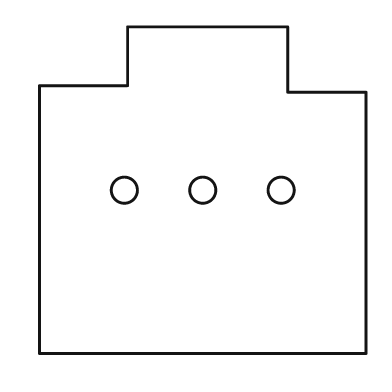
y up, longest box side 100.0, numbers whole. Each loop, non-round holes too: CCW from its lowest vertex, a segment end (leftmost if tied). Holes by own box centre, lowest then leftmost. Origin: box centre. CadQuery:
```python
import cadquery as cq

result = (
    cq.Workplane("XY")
    .moveTo(-50.0, -50.0)
    .lineTo(50.0, -50.0)
    .lineTo(50.0, 30.0)
    .lineTo(26.0, 30.0)
    .lineTo(26.0, 50.0)
    .lineTo(-23.0, 50.0)
    .lineTo(-23.0, 32.0)
    .lineTo(-50.0, 32.0)
    .close()
    .moveTo(-24.0, 0.0)
    .circle(4.0)
    .moveTo(0.0, 0.0)
    .circle(4.0)
    .moveTo(24.0, 0.0)
    .circle(4.0)
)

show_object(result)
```